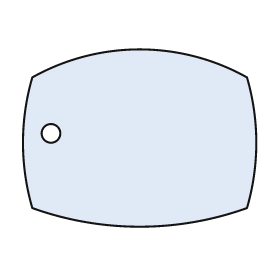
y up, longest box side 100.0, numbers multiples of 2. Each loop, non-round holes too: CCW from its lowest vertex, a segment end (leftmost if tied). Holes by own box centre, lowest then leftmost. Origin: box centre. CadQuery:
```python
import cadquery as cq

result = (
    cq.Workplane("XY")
    .moveTo(-46.0, -30.0)
    .threePointArc((0.0, -38.0), (46.0, -30.0))
    .threePointArc((50.0, -2.0), (46.0, 26.0))
    .threePointArc((0.0, 38.0), (-46.0, 26.0))
    .threePointArc((-50.0, -2.0), (-46.0, -30.0))
    .close()
    .moveTo(-38.0, 2.0)
    .circle(4.0)
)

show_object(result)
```